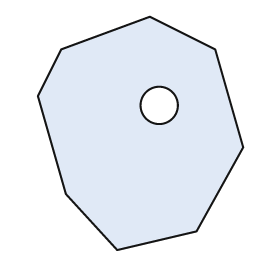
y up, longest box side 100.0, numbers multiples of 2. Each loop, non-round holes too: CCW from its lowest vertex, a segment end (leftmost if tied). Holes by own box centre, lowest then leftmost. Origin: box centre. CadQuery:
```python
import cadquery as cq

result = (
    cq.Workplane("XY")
    .moveTo(-10.0, -50.0)
    .lineTo(24.0, -42.0)
    .lineTo(44.0, -6.0)
    .lineTo(32.0, 36.0)
    .lineTo(4.0, 50.0)
    .lineTo(-34.0, 36.0)
    .lineTo(-44.0, 16.0)
    .lineTo(-32.0, -26.0)
    .close()
    .moveTo(8.0, 12.0)
    .circle(8.0)
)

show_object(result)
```